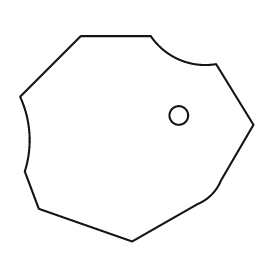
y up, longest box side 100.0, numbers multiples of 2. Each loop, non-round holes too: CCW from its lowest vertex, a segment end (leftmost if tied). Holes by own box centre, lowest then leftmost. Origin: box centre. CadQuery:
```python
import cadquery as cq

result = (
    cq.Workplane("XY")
    .moveTo(-2.0, -44.0)
    .lineTo(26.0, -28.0)
    .threePointArc((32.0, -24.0), (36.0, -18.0))
    .lineTo(50.0, 6.0)
    .lineTo(34.0, 32.0)
    .threePointArc((18.0, 34.0), (6.0, 44.0))
    .lineTo(-24.0, 44.0)
    .lineTo(-50.0, 18.0)
    .threePointArc((-46.0, 2.0), (-48.0, -14.0))
    .lineTo(-42.0, -30.0)
    .close()
    .moveTo(18.0, 10.0)
    .circle(4.0)
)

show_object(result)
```